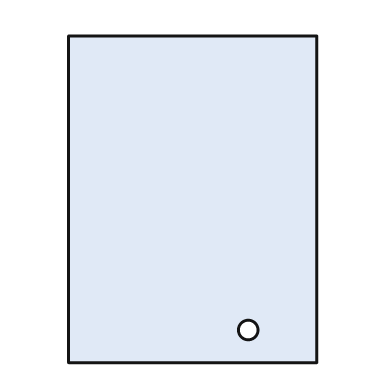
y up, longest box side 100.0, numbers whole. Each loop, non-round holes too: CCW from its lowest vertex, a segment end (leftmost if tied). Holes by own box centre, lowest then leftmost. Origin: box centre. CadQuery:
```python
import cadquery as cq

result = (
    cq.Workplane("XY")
    .moveTo(-38.0, -50.0)
    .lineTo(38.0, -50.0)
    .lineTo(38.0, 50.0)
    .lineTo(-38.0, 50.0)
    .close()
    .moveTo(17.0, -40.0)
    .circle(3.0)
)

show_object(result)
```